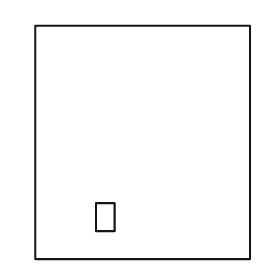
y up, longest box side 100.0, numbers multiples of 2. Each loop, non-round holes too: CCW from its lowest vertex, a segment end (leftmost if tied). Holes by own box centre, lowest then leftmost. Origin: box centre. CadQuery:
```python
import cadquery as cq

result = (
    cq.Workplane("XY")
    .moveTo(-46.0, -50.0)
    .lineTo(46.0, -50.0)
    .lineTo(46.0, 50.0)
    .lineTo(-46.0, 50.0)
    .close()
    .moveTo(-20.0, -38.0)
    .lineTo(-12.0, -38.0)
    .lineTo(-12.0, -26.0)
    .lineTo(-20.0, -26.0)
    .close()
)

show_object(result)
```